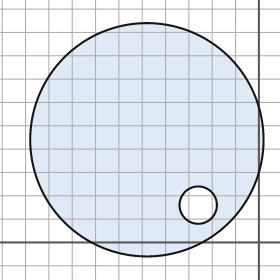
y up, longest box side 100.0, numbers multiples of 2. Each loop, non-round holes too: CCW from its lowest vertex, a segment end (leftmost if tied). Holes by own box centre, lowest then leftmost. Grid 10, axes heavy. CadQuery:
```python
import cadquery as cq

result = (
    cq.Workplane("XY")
    .moveTo(-48.0, 44.0)
    .circle(50.0)
    .moveTo(-26.0, 16.0)
    .circle(8.0)
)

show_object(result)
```